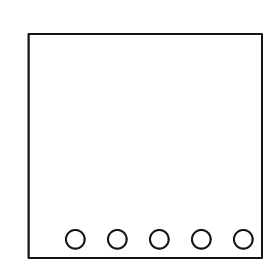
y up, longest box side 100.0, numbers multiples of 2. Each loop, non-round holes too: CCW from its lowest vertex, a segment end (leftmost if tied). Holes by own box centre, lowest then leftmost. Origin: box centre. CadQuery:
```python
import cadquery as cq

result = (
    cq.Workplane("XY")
    .moveTo(-50.0, -48.0)
    .lineTo(50.0, -48.0)
    .lineTo(50.0, 48.0)
    .lineTo(-50.0, 48.0)
    .close()
    .moveTo(-30.0, -40.0)
    .circle(4.0)
    .moveTo(-12.0, -40.0)
    .circle(4.0)
    .moveTo(6.0, -40.0)
    .circle(4.0)
    .moveTo(24.0, -40.0)
    .circle(4.0)
    .moveTo(42.0, -40.0)
    .circle(4.0)
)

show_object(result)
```